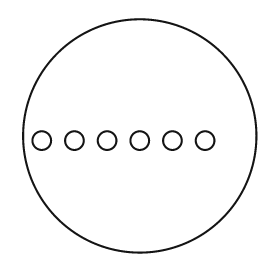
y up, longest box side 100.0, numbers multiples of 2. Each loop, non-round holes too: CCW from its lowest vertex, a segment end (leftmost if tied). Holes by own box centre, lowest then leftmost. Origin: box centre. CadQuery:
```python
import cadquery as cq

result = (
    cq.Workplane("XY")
    .moveTo(0.0, 0.0)
    .circle(50.0)
    .moveTo(-42.0, -2.0)
    .circle(4.0)
    .moveTo(-28.0, -2.0)
    .circle(4.0)
    .moveTo(-14.0, -2.0)
    .circle(4.0)
    .moveTo(0.0, -2.0)
    .circle(4.0)
    .moveTo(14.0, -2.0)
    .circle(4.0)
    .moveTo(28.0, -2.0)
    .circle(4.0)
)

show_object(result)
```